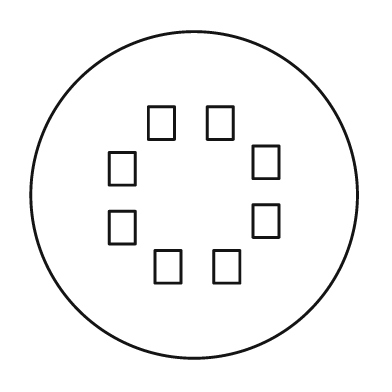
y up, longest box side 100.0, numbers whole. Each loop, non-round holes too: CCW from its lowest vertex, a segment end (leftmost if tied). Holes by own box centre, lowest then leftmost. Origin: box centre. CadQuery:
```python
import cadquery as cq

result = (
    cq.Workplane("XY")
    .moveTo(0.0, 0.0)
    .circle(50.0)
    .moveTo(-12.0, -27.0)
    .lineTo(-4.0, -27.0)
    .lineTo(-4.0, -17.0)
    .lineTo(-12.0, -17.0)
    .close()
    .moveTo(6.0, -27.0)
    .lineTo(14.0, -27.0)
    .lineTo(14.0, -17.0)
    .lineTo(6.0, -17.0)
    .close()
    .moveTo(-26.0, -15.0)
    .lineTo(-18.0, -15.0)
    .lineTo(-18.0, -5.0)
    .lineTo(-26.0, -5.0)
    .close()
    .moveTo(18.0, -13.0)
    .lineTo(26.0, -13.0)
    .lineTo(26.0, -3.0)
    .lineTo(18.0, -3.0)
    .close()
    .moveTo(-26.0, 3.0)
    .lineTo(-18.0, 3.0)
    .lineTo(-18.0, 13.0)
    .lineTo(-26.0, 13.0)
    .close()
    .moveTo(18.0, 5.0)
    .lineTo(26.0, 5.0)
    .lineTo(26.0, 15.0)
    .lineTo(18.0, 15.0)
    .close()
    .moveTo(-14.0, 17.0)
    .lineTo(-6.0, 17.0)
    .lineTo(-6.0, 27.0)
    .lineTo(-14.0, 27.0)
    .close()
    .moveTo(4.0, 17.0)
    .lineTo(12.0, 17.0)
    .lineTo(12.0, 27.0)
    .lineTo(4.0, 27.0)
    .close()
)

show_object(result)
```